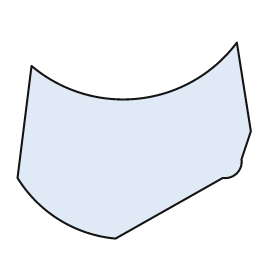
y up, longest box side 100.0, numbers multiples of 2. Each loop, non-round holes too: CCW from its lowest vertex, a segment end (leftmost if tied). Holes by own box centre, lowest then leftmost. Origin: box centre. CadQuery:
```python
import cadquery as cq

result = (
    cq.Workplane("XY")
    .moveTo(-8.0, -42.0)
    .lineTo(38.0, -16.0)
    .threePointArc((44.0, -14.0), (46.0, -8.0))
    .lineTo(50.0, 4.0)
    .lineTo(44.0, 42.0)
    .threePointArc((2.0, 18.0), (-44.0, 32.0))
    .lineTo(-50.0, -16.0)
    .threePointArc((-32.0, -34.0), (-8.0, -42.0))
    .close()
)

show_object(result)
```